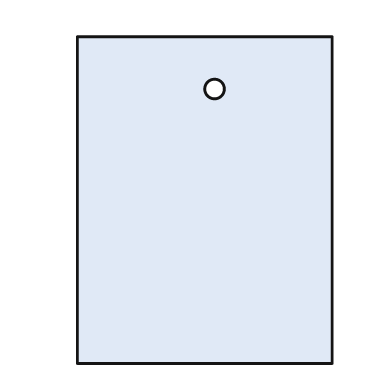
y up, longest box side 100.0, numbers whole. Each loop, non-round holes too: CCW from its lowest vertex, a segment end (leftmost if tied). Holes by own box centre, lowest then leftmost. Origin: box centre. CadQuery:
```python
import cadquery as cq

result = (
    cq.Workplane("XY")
    .moveTo(-39.0, -50.0)
    .lineTo(39.0, -50.0)
    .lineTo(39.0, 50.0)
    .lineTo(-39.0, 50.0)
    .close()
    .moveTo(3.0, 34.0)
    .circle(3.0)
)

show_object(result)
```